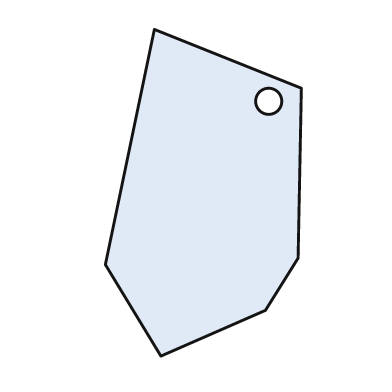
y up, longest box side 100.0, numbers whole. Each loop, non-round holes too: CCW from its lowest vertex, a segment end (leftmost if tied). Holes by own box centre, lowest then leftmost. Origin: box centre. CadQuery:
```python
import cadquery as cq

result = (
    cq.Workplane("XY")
    .moveTo(-13.0, -50.0)
    .lineTo(19.0, -36.0)
    .lineTo(29.0, -20.0)
    .lineTo(30.0, 32.0)
    .lineTo(-15.0, 50.0)
    .lineTo(-30.0, -22.0)
    .close()
    .moveTo(20.0, 28.0)
    .circle(4.0)
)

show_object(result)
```